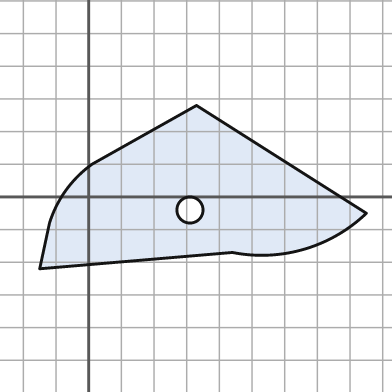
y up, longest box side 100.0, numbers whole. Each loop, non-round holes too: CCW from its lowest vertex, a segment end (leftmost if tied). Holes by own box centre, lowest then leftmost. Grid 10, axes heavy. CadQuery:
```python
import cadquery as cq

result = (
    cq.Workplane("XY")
    .moveTo(-15.0, -22.0)
    .lineTo(44.0, -17.0)
    .threePointArc((66.0, -16.0), (85.0, -5.0))
    .lineTo(33.0, 28.0)
    .lineTo(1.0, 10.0)
    .threePointArc((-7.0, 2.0), (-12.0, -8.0))
    .close()
    .moveTo(31.0, -4.0)
    .circle(4.0)
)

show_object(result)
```